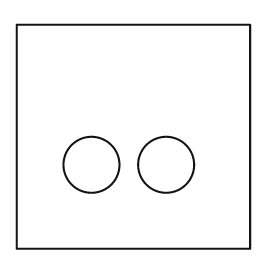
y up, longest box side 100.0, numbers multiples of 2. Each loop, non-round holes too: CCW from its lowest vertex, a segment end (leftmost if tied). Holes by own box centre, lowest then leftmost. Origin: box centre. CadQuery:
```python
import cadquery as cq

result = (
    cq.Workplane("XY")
    .moveTo(-50.0, -48.0)
    .lineTo(50.0, -48.0)
    .lineTo(50.0, 48.0)
    .lineTo(-50.0, 48.0)
    .close()
    .moveTo(-18.0, -12.0)
    .circle(12.0)
    .moveTo(14.0, -12.0)
    .circle(12.0)
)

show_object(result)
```